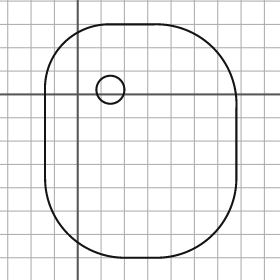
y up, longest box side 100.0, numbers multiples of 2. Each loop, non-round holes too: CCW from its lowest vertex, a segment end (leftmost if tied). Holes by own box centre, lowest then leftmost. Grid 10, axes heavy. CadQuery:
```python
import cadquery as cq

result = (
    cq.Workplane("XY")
    .moveTo(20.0, -70.0)
    .lineTo(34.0, -70.0)
    .threePointArc((58.0, -60.0), (68.0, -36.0))
    .lineTo(68.0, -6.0)
    .threePointArc((58.0, 20.0), (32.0, 30.0))
    .lineTo(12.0, 30.0)
    .threePointArc((-6.0, 22.0), (-14.0, 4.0))
    .lineTo(-14.0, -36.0)
    .threePointArc((-4.0, -60.0), (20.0, -70.0))
    .close()
    .moveTo(14.0, 2.0)
    .circle(6.0)
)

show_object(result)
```